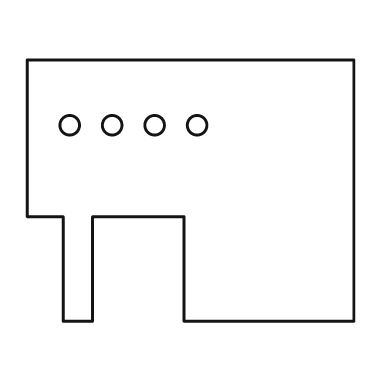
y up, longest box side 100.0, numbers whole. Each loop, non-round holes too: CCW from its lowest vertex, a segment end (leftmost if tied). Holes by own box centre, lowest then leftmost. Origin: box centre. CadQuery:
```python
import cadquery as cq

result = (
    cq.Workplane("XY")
    .moveTo(-39.0, -40.0)
    .lineTo(-30.0, -40.0)
    .lineTo(-30.0, -8.0)
    .lineTo(-2.0, -8.0)
    .lineTo(-2.0, -40.0)
    .lineTo(50.0, -40.0)
    .lineTo(50.0, 40.0)
    .lineTo(-50.0, 40.0)
    .lineTo(-50.0, -8.0)
    .lineTo(-39.0, -8.0)
    .close()
    .moveTo(-37.0, 20.0)
    .circle(3.0)
    .moveTo(-24.0, 20.0)
    .circle(3.0)
    .moveTo(-11.0, 20.0)
    .circle(3.0)
    .moveTo(2.0, 20.0)
    .circle(3.0)
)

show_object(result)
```